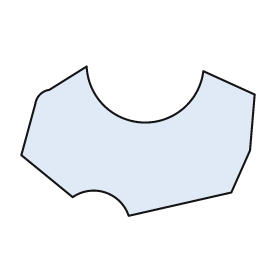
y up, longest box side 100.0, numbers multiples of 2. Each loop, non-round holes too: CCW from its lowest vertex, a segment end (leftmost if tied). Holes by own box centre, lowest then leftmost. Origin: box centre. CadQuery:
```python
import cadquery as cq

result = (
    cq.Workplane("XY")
    .moveTo(-4.0, -32.0)
    .lineTo(40.0, -22.0)
    .lineTo(48.0, -4.0)
    .lineTo(50.0, 20.0)
    .lineTo(28.0, 30.0)
    .threePointArc((2.0, 8.0), (-22.0, 32.0))
    .lineTo(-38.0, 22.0)
    .threePointArc((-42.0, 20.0), (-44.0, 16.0))
    .lineTo(-50.0, -6.0)
    .lineTo(-28.0, -24.0)
    .threePointArc((-14.0, -22.0), (-4.0, -32.0))
    .close()
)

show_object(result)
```